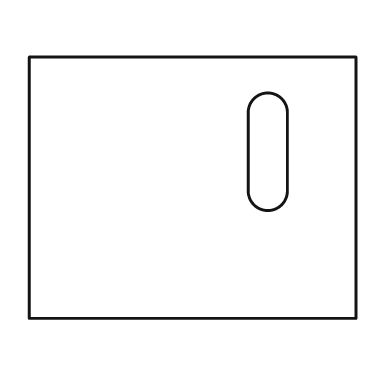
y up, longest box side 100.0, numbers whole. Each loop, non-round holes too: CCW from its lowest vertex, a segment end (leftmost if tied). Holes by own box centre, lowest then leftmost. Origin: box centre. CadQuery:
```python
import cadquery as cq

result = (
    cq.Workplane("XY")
    .moveTo(-50.0, -40.0)
    .lineTo(50.0, -40.0)
    .lineTo(50.0, 40.0)
    .lineTo(-50.0, 40.0)
    .close()
    .moveTo(17.0, -1.0)
    .threePointArc((23.0, -7.0), (29.0, -1.0))
    .lineTo(29.0, 23.0)
    .threePointArc((23.0, 29.0), (17.0, 23.0))
    .close()
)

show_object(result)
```